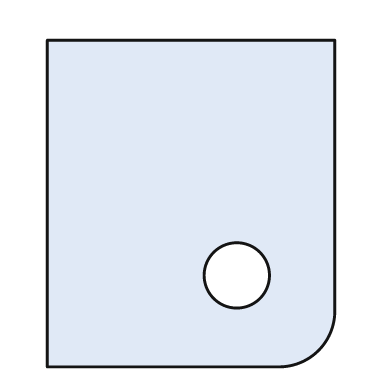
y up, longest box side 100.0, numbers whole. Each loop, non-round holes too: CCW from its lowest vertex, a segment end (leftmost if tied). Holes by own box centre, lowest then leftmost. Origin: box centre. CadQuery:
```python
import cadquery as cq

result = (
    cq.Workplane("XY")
    .moveTo(-44.0, -50.0)
    .lineTo(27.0, -50.0)
    .threePointArc((39.0, -45.0), (44.0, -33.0))
    .lineTo(44.0, 50.0)
    .lineTo(-44.0, 50.0)
    .close()
    .moveTo(14.0, -22.0)
    .circle(10.0)
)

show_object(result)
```